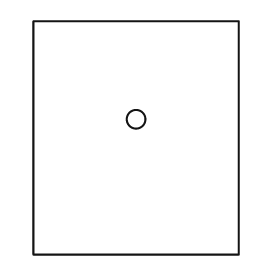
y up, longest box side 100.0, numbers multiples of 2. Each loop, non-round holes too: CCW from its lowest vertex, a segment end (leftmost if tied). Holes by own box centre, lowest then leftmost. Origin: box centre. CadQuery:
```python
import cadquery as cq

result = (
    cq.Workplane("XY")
    .moveTo(-44.0, -50.0)
    .lineTo(44.0, -50.0)
    .lineTo(44.0, 50.0)
    .lineTo(-44.0, 50.0)
    .close()
    .moveTo(0.0, 8.0)
    .circle(4.0)
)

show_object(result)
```